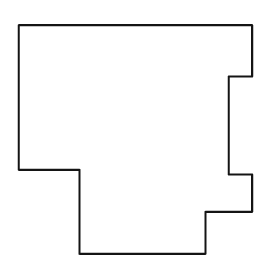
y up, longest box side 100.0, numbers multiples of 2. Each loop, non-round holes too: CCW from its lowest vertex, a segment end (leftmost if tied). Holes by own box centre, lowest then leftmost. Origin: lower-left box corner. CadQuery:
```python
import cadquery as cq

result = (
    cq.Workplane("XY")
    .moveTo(26.0, 0.0)
    .lineTo(80.0, 0.0)
    .lineTo(80.0, 18.0)
    .lineTo(100.0, 18.0)
    .lineTo(100.0, 34.0)
    .lineTo(90.0, 34.0)
    .lineTo(90.0, 76.0)
    .lineTo(100.0, 76.0)
    .lineTo(100.0, 98.0)
    .lineTo(0.0, 98.0)
    .lineTo(0.0, 36.0)
    .lineTo(26.0, 36.0)
    .close()
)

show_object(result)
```